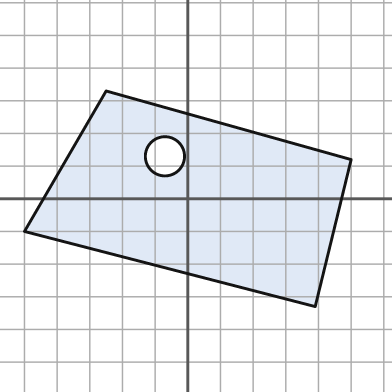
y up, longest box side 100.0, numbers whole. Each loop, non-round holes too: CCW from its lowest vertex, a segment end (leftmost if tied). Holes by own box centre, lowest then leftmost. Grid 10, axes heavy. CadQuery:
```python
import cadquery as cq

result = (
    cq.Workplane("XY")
    .moveTo(39.0, -33.0)
    .lineTo(50.0, 12.0)
    .lineTo(-25.0, 33.0)
    .lineTo(-50.0, -10.0)
    .close()
    .moveTo(-7.0, 13.0)
    .circle(6.0)
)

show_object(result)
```